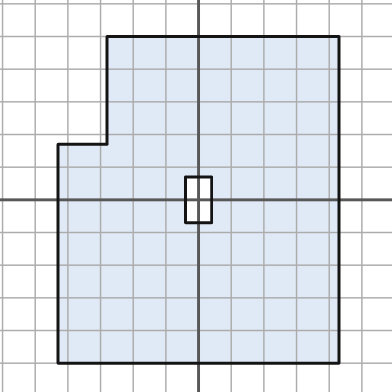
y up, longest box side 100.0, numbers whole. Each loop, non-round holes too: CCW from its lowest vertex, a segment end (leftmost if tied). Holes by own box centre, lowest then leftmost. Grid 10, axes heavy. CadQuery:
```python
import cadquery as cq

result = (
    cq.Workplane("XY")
    .moveTo(-43.0, -50.0)
    .lineTo(43.0, -50.0)
    .lineTo(43.0, 50.0)
    .lineTo(-28.0, 50.0)
    .lineTo(-28.0, 17.0)
    .lineTo(-43.0, 17.0)
    .close()
    .moveTo(-4.0, -7.0)
    .lineTo(4.0, -7.0)
    .lineTo(4.0, 7.0)
    .lineTo(-4.0, 7.0)
    .close()
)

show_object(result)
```